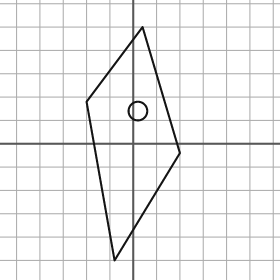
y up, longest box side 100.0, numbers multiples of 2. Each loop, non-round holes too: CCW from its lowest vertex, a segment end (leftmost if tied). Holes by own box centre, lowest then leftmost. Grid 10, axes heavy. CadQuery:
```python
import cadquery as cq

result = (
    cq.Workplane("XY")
    .moveTo(-8.0, -50.0)
    .lineTo(20.0, -4.0)
    .lineTo(4.0, 50.0)
    .lineTo(-20.0, 18.0)
    .close()
    .moveTo(2.0, 14.0)
    .circle(4.0)
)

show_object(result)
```